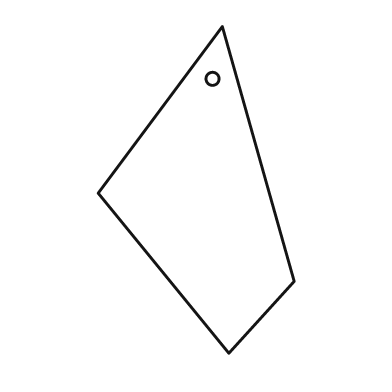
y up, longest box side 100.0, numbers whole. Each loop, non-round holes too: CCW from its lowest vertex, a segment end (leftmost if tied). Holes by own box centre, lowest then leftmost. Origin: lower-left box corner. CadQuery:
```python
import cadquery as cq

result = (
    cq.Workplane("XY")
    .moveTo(40.0, 0.0)
    .lineTo(60.0, 22.0)
    .lineTo(38.0, 100.0)
    .lineTo(0.0, 49.0)
    .close()
    .moveTo(35.0, 84.0)
    .circle(2.0)
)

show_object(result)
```